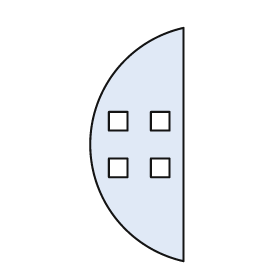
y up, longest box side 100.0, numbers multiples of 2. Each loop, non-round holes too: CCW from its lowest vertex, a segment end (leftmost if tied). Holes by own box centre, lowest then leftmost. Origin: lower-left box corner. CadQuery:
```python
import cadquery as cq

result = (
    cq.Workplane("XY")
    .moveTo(40.0, 0.0)
    .lineTo(40.0, 100.0)
    .threePointArc((0.0, 50.0), (40.0, 0.0))
    .close()
    .moveTo(8.0, 36.0)
    .lineTo(16.0, 36.0)
    .lineTo(16.0, 44.0)
    .lineTo(8.0, 44.0)
    .close()
    .moveTo(26.0, 36.0)
    .lineTo(34.0, 36.0)
    .lineTo(34.0, 44.0)
    .lineTo(26.0, 44.0)
    .close()
    .moveTo(8.0, 56.0)
    .lineTo(16.0, 56.0)
    .lineTo(16.0, 64.0)
    .lineTo(8.0, 64.0)
    .close()
    .moveTo(26.0, 56.0)
    .lineTo(34.0, 56.0)
    .lineTo(34.0, 64.0)
    .lineTo(26.0, 64.0)
    .close()
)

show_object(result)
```